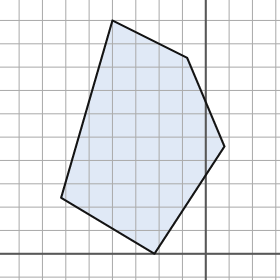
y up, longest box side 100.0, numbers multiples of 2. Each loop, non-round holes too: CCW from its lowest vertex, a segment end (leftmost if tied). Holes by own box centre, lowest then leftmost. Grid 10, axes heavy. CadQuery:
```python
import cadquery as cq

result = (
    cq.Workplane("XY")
    .moveTo(-22.0, 0.0)
    .lineTo(8.0, 46.0)
    .lineTo(-8.0, 84.0)
    .lineTo(-40.0, 100.0)
    .lineTo(-62.0, 24.0)
    .close()
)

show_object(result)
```